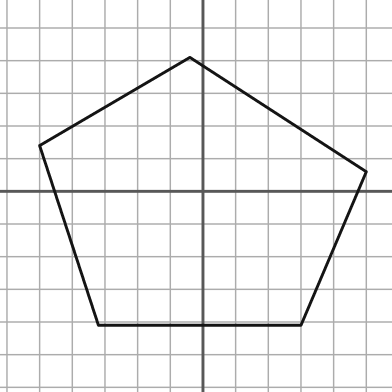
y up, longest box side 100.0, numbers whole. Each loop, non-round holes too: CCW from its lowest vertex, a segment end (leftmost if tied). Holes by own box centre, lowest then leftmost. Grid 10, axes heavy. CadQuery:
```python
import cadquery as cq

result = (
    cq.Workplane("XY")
    .moveTo(-32.0, -41.0)
    .lineTo(30.0, -41.0)
    .lineTo(50.0, 6.0)
    .lineTo(-4.0, 41.0)
    .lineTo(-50.0, 14.0)
    .close()
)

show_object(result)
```